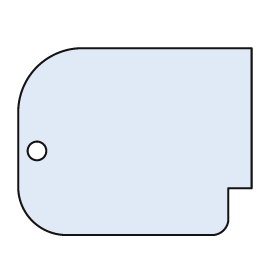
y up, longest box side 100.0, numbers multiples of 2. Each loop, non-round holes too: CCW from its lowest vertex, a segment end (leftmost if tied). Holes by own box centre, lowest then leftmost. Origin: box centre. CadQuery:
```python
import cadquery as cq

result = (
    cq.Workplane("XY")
    .moveTo(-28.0, -40.0)
    .lineTo(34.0, -40.0)
    .threePointArc((38.0, -38.0), (40.0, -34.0))
    .lineTo(40.0, -20.0)
    .lineTo(50.0, -20.0)
    .lineTo(50.0, 40.0)
    .lineTo(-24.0, 40.0)
    .threePointArc((-42.0, 32.0), (-50.0, 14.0))
    .lineTo(-50.0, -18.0)
    .threePointArc((-44.0, -34.0), (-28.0, -40.0))
    .close()
    .moveTo(-42.0, -4.0)
    .circle(4.0)
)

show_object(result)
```